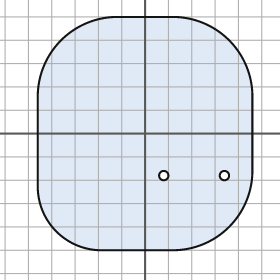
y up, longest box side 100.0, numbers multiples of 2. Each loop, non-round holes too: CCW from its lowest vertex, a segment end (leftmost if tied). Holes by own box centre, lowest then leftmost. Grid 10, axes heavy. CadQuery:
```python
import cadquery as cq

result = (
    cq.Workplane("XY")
    .moveTo(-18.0, -50.0)
    .lineTo(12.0, -50.0)
    .threePointArc((36.0, -40.0), (46.0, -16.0))
    .lineTo(46.0, 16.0)
    .threePointArc((36.0, 40.0), (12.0, 50.0))
    .lineTo(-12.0, 50.0)
    .threePointArc((-36.0, 40.0), (-46.0, 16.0))
    .lineTo(-46.0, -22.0)
    .threePointArc((-38.0, -42.0), (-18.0, -50.0))
    .close()
    .moveTo(8.0, -18.0)
    .circle(2.0)
    .moveTo(34.0, -18.0)
    .circle(2.0)
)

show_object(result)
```